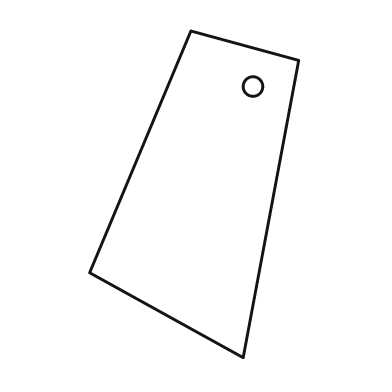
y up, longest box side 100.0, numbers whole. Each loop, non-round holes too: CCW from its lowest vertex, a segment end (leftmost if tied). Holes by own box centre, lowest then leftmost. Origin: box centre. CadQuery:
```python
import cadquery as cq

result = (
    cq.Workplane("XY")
    .moveTo(15.0, -50.0)
    .lineTo(32.0, 41.0)
    .lineTo(-1.0, 50.0)
    .lineTo(-32.0, -24.0)
    .close()
    .moveTo(18.0, 33.0)
    .circle(3.0)
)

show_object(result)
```